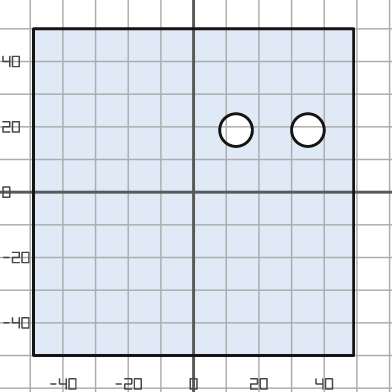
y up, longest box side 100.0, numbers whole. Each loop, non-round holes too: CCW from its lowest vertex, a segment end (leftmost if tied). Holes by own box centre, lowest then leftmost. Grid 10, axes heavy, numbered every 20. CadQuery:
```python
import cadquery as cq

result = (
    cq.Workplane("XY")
    .moveTo(-49.0, -50.0)
    .lineTo(49.0, -50.0)
    .lineTo(49.0, 50.0)
    .lineTo(-49.0, 50.0)
    .close()
    .moveTo(13.0, 19.0)
    .circle(5.0)
    .moveTo(35.0, 19.0)
    .circle(5.0)
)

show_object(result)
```